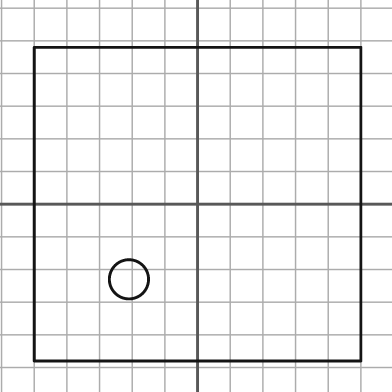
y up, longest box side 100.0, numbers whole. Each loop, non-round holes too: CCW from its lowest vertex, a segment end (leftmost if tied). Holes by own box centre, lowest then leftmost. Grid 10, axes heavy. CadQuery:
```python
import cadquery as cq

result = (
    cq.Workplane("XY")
    .moveTo(-50.0, -48.0)
    .lineTo(50.0, -48.0)
    .lineTo(50.0, 48.0)
    .lineTo(-50.0, 48.0)
    .close()
    .moveTo(-21.0, -23.0)
    .circle(6.0)
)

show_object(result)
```